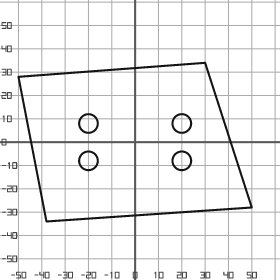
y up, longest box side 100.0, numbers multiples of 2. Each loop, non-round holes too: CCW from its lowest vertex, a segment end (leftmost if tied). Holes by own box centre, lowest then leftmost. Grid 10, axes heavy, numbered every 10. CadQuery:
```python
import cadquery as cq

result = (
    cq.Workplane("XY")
    .moveTo(-38.0, -34.0)
    .lineTo(50.0, -28.0)
    .lineTo(30.0, 34.0)
    .lineTo(-50.0, 28.0)
    .close()
    .moveTo(-20.0, -8.0)
    .circle(4.0)
    .moveTo(20.0, -8.0)
    .circle(4.0)
    .moveTo(-20.0, 8.0)
    .circle(4.0)
    .moveTo(20.0, 8.0)
    .circle(4.0)
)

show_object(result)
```